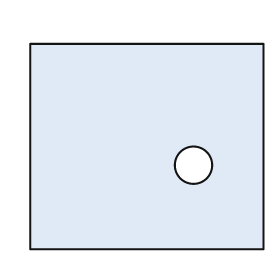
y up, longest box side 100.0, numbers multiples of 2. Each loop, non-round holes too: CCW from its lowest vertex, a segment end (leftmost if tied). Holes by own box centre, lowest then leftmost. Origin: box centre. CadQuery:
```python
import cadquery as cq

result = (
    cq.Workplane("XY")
    .moveTo(-50.0, -44.0)
    .lineTo(50.0, -44.0)
    .lineTo(50.0, 44.0)
    .lineTo(-50.0, 44.0)
    .close()
    .moveTo(20.0, -8.0)
    .circle(8.0)
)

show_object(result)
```